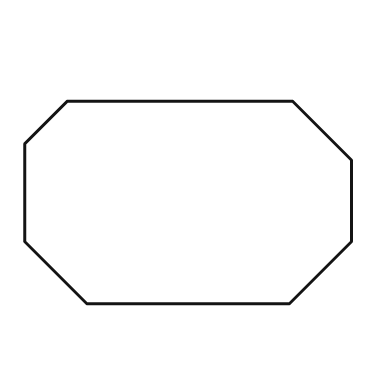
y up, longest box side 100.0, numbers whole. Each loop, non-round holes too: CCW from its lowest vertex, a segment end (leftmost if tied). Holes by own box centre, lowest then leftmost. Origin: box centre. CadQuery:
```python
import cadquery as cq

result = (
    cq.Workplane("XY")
    .moveTo(-31.0, -31.0)
    .lineTo(31.0, -31.0)
    .lineTo(50.0, -12.0)
    .lineTo(50.0, 13.0)
    .lineTo(32.0, 31.0)
    .lineTo(-37.0, 31.0)
    .lineTo(-50.0, 18.0)
    .lineTo(-50.0, -12.0)
    .close()
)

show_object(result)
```